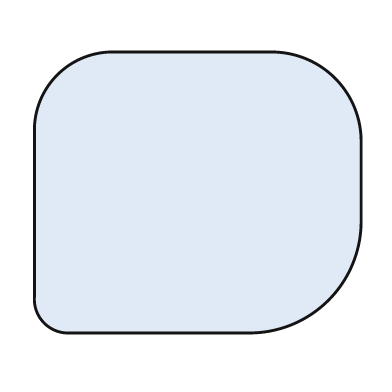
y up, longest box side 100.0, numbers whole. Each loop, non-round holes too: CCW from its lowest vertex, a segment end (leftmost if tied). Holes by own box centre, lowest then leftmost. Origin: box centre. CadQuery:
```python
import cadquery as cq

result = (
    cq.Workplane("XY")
    .moveTo(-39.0, -43.0)
    .lineTo(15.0, -43.0)
    .threePointArc((40.0, -33.0), (50.0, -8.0))
    .lineTo(50.0, 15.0)
    .threePointArc((42.0, 35.0), (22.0, 43.0))
    .lineTo(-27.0, 43.0)
    .threePointArc((-43.0, 36.0), (-50.0, 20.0))
    .lineTo(-50.0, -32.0)
    .threePointArc((-47.0, -40.0), (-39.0, -43.0))
    .close()
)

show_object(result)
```